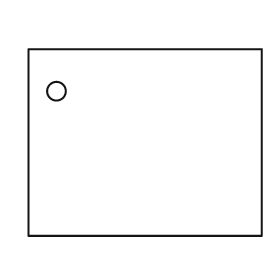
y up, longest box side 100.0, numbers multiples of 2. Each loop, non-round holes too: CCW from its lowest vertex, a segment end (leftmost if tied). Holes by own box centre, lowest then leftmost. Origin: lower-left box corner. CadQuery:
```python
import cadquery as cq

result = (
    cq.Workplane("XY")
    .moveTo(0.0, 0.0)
    .lineTo(100.0, 0.0)
    .lineTo(100.0, 80.0)
    .lineTo(0.0, 80.0)
    .close()
    .moveTo(12.0, 62.0)
    .circle(4.0)
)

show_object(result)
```